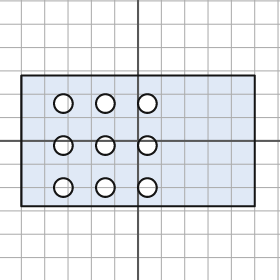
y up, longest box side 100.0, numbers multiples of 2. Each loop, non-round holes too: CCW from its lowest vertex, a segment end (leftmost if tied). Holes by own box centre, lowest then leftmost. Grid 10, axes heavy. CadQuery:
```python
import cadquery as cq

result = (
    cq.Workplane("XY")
    .moveTo(-50.0, -28.0)
    .lineTo(50.0, -28.0)
    .lineTo(50.0, 28.0)
    .lineTo(-50.0, 28.0)
    .close()
    .moveTo(-32.0, -20.0)
    .circle(4.0)
    .moveTo(-14.0, -20.0)
    .circle(4.0)
    .moveTo(4.0, -20.0)
    .circle(4.0)
    .moveTo(-32.0, -2.0)
    .circle(4.0)
    .moveTo(-14.0, -2.0)
    .circle(4.0)
    .moveTo(4.0, -2.0)
    .circle(4.0)
    .moveTo(-32.0, 16.0)
    .circle(4.0)
    .moveTo(-14.0, 16.0)
    .circle(4.0)
    .moveTo(4.0, 16.0)
    .circle(4.0)
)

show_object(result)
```